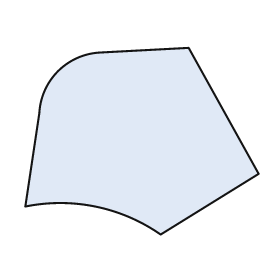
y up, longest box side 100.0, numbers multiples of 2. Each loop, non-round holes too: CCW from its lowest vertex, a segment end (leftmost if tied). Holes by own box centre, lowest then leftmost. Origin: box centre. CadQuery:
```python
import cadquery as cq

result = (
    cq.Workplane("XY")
    .moveTo(8.0, -40.0)
    .lineTo(50.0, -14.0)
    .lineTo(20.0, 40.0)
    .lineTo(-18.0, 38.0)
    .threePointArc((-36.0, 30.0), (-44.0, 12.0))
    .lineTo(-50.0, -28.0)
    .threePointArc((-20.0, -28.0), (8.0, -40.0))
    .close()
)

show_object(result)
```